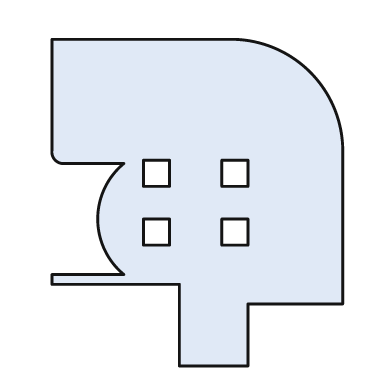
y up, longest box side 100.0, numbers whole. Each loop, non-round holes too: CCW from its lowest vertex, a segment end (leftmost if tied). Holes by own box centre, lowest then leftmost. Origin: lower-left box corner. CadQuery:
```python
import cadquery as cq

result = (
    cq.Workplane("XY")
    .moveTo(39.0, 0.0)
    .lineTo(60.0, 0.0)
    .lineTo(60.0, 19.0)
    .lineTo(89.0, 19.0)
    .lineTo(89.0, 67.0)
    .threePointArc((79.0, 90.0), (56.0, 100.0))
    .lineTo(0.0, 100.0)
    .lineTo(0.0, 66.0)
    .threePointArc((1.0, 63.0), (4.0, 62.0))
    .lineTo(22.0, 62.0)
    .threePointArc((14.0, 45.0), (22.0, 28.0))
    .lineTo(0.0, 28.0)
    .lineTo(0.0, 25.0)
    .lineTo(39.0, 25.0)
    .close()
    .moveTo(28.0, 37.0)
    .lineTo(36.0, 37.0)
    .lineTo(36.0, 45.0)
    .lineTo(28.0, 45.0)
    .close()
    .moveTo(52.0, 37.0)
    .lineTo(60.0, 37.0)
    .lineTo(60.0, 45.0)
    .lineTo(52.0, 45.0)
    .close()
    .moveTo(28.0, 55.0)
    .lineTo(36.0, 55.0)
    .lineTo(36.0, 63.0)
    .lineTo(28.0, 63.0)
    .close()
    .moveTo(52.0, 55.0)
    .lineTo(60.0, 55.0)
    .lineTo(60.0, 63.0)
    .lineTo(52.0, 63.0)
    .close()
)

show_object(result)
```